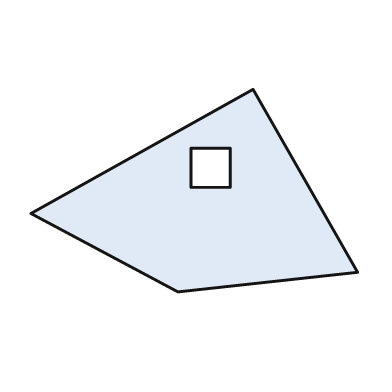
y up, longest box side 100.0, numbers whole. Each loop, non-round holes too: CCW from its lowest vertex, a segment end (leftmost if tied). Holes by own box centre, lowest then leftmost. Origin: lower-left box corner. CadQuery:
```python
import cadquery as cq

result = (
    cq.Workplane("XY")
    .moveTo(45.0, 0.0)
    .lineTo(100.0, 6.0)
    .lineTo(68.0, 62.0)
    .lineTo(0.0, 24.0)
    .close()
    .moveTo(49.0, 32.0)
    .lineTo(61.0, 32.0)
    .lineTo(61.0, 44.0)
    .lineTo(49.0, 44.0)
    .close()
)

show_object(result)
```